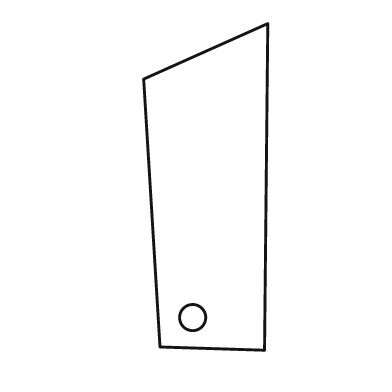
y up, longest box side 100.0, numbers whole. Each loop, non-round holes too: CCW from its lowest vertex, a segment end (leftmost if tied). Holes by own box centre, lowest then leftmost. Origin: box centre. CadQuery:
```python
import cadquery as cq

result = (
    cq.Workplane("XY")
    .moveTo(18.0, -50.0)
    .lineTo(19.0, 50.0)
    .lineTo(-19.0, 33.0)
    .lineTo(-14.0, -49.0)
    .close()
    .moveTo(-4.0, -40.0)
    .circle(4.0)
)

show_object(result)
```